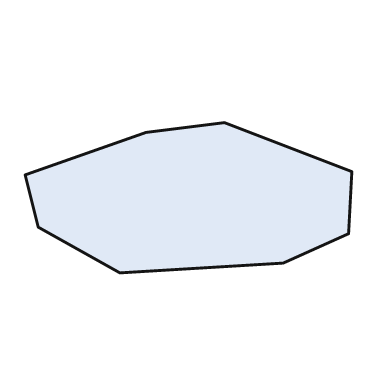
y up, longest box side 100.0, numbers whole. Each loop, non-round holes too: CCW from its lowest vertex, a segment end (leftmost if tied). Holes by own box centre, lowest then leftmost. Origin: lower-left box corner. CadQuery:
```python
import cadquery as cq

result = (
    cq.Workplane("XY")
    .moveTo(29.0, 0.0)
    .lineTo(79.0, 3.0)
    .lineTo(99.0, 12.0)
    .lineTo(100.0, 31.0)
    .lineTo(61.0, 46.0)
    .lineTo(37.0, 43.0)
    .lineTo(0.0, 30.0)
    .lineTo(4.0, 14.0)
    .close()
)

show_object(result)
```